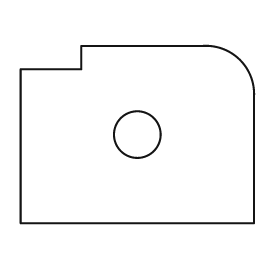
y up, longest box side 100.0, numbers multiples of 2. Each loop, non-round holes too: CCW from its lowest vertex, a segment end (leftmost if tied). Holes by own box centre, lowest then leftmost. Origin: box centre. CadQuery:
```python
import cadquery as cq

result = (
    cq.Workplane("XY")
    .moveTo(-50.0, -38.0)
    .lineTo(50.0, -38.0)
    .lineTo(50.0, 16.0)
    .threePointArc((44.0, 32.0), (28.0, 38.0))
    .lineTo(-24.0, 38.0)
    .lineTo(-24.0, 28.0)
    .lineTo(-50.0, 28.0)
    .close()
    .moveTo(0.0, 0.0)
    .circle(10.0)
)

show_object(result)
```